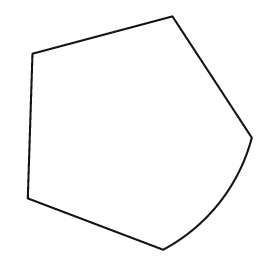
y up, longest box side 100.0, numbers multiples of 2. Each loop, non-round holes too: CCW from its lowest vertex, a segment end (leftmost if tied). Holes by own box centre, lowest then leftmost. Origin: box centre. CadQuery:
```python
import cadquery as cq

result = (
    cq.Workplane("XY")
    .moveTo(10.0, -50.0)
    .threePointArc((34.0, -30.0), (48.0, -2.0))
    .lineTo(14.0, 50.0)
    .lineTo(-46.0, 34.0)
    .lineTo(-48.0, -28.0)
    .close()
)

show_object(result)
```